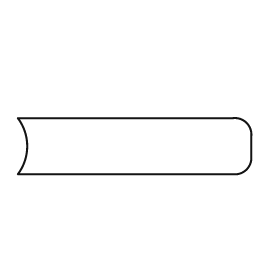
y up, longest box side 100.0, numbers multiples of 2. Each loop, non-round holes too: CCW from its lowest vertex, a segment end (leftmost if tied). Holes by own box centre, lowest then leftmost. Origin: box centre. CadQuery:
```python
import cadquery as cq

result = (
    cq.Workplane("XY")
    .moveTo(-50.0, -12.0)
    .lineTo(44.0, -12.0)
    .threePointArc((48.0, -10.0), (50.0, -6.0))
    .lineTo(50.0, 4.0)
    .threePointArc((48.0, 10.0), (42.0, 12.0))
    .lineTo(-50.0, 12.0)
    .threePointArc((-46.0, 0.0), (-50.0, -12.0))
    .close()
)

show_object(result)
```